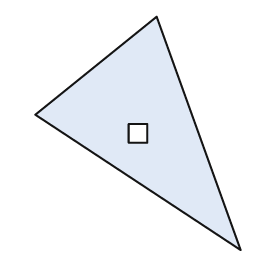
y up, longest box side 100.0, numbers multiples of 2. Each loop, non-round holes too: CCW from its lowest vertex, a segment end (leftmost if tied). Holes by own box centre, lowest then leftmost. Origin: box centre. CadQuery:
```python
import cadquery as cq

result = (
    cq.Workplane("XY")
    .moveTo(44.0, -50.0)
    .lineTo(8.0, 50.0)
    .lineTo(-44.0, 8.0)
    .close()
    .moveTo(-4.0, -4.0)
    .lineTo(4.0, -4.0)
    .lineTo(4.0, 4.0)
    .lineTo(-4.0, 4.0)
    .close()
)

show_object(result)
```